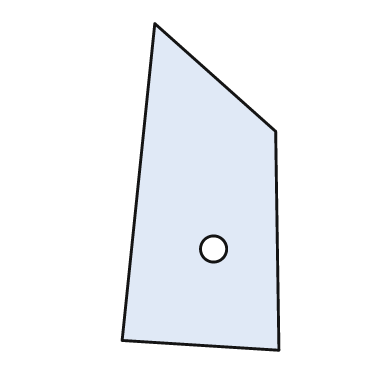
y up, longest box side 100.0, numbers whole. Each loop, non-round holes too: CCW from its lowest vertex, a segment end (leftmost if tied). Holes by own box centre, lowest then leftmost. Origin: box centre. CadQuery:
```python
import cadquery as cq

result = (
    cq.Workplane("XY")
    .moveTo(24.0, -50.0)
    .lineTo(23.0, 17.0)
    .lineTo(-14.0, 50.0)
    .lineTo(-24.0, -47.0)
    .close()
    .moveTo(4.0, -19.0)
    .circle(4.0)
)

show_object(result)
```